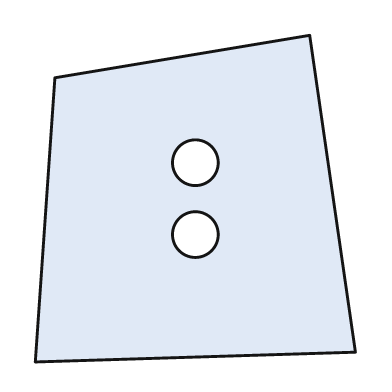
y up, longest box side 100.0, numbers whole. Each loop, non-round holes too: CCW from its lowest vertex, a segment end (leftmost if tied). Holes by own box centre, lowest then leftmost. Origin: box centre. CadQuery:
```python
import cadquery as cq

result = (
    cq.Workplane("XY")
    .moveTo(-49.0, -50.0)
    .lineTo(49.0, -47.0)
    .lineTo(35.0, 50.0)
    .lineTo(-43.0, 37.0)
    .close()
    .moveTo(0.0, -11.0)
    .circle(7.0)
    .moveTo(0.0, 11.0)
    .circle(7.0)
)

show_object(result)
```